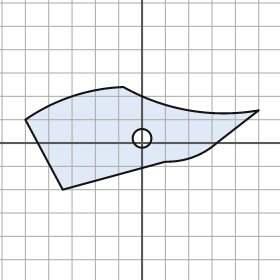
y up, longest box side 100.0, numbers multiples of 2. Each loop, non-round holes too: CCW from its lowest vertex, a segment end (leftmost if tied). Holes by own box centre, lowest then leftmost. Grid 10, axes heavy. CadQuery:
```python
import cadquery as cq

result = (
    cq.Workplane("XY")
    .moveTo(-34.0, -20.0)
    .lineTo(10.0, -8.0)
    .threePointArc((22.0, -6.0), (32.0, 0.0))
    .lineTo(50.0, 14.0)
    .threePointArc((20.0, 14.0), (-8.0, 24.0))
    .threePointArc((-30.0, 20.0), (-50.0, 10.0))
    .close()
    .moveTo(0.0, 2.0)
    .circle(4.0)
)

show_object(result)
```